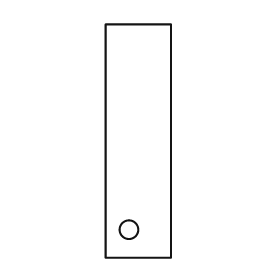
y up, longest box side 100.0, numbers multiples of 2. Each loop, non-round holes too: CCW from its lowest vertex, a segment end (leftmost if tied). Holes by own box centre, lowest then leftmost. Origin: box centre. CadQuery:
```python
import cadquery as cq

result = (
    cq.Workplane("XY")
    .moveTo(-14.0, -50.0)
    .lineTo(14.0, -50.0)
    .lineTo(14.0, 50.0)
    .lineTo(-14.0, 50.0)
    .close()
    .moveTo(-4.0, -38.0)
    .circle(4.0)
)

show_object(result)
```